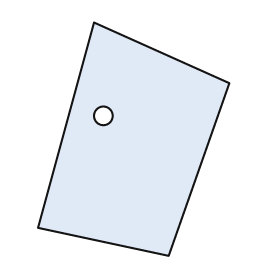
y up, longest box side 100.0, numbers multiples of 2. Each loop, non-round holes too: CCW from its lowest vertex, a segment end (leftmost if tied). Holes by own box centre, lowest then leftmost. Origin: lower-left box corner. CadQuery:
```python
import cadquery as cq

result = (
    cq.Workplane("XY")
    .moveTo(56.0, 0.0)
    .lineTo(82.0, 74.0)
    .lineTo(24.0, 100.0)
    .lineTo(0.0, 12.0)
    .close()
    .moveTo(28.0, 60.0)
    .circle(4.0)
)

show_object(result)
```